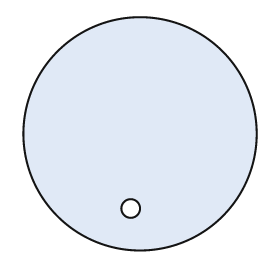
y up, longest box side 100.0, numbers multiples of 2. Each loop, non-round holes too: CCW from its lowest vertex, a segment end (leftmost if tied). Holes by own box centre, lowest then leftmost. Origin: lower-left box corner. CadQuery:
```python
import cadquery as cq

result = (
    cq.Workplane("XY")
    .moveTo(50.0, 50.0)
    .circle(50.0)
    .moveTo(46.0, 18.0)
    .circle(4.0)
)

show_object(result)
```